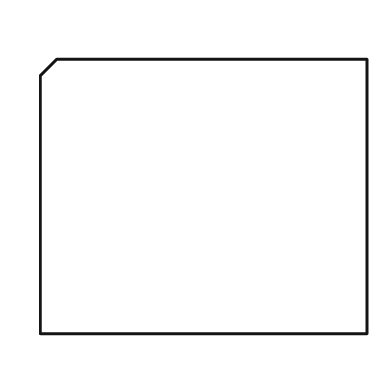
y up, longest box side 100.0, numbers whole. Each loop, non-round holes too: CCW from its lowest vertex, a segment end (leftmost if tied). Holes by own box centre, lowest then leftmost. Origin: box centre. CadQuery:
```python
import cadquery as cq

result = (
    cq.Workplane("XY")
    .moveTo(-50.0, -42.0)
    .lineTo(50.0, -42.0)
    .lineTo(50.0, 42.0)
    .lineTo(-45.0, 42.0)
    .lineTo(-50.0, 37.0)
    .close()
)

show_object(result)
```